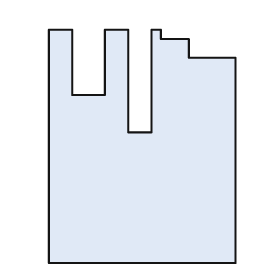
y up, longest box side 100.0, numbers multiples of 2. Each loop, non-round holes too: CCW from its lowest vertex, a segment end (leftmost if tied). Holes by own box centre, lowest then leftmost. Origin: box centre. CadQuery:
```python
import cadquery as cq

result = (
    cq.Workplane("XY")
    .moveTo(-40.0, -50.0)
    .lineTo(40.0, -50.0)
    .lineTo(40.0, 38.0)
    .lineTo(20.0, 38.0)
    .lineTo(20.0, 46.0)
    .lineTo(8.0, 46.0)
    .lineTo(8.0, 50.0)
    .lineTo(4.0, 50.0)
    .lineTo(4.0, 6.0)
    .lineTo(-6.0, 6.0)
    .lineTo(-6.0, 50.0)
    .lineTo(-16.0, 50.0)
    .lineTo(-16.0, 22.0)
    .lineTo(-30.0, 22.0)
    .lineTo(-30.0, 50.0)
    .lineTo(-40.0, 50.0)
    .close()
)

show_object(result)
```